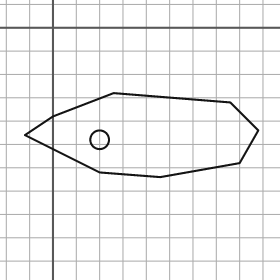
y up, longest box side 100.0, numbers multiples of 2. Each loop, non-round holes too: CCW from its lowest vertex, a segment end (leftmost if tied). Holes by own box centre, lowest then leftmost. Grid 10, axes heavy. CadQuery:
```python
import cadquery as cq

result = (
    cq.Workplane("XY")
    .moveTo(46.0, -64.0)
    .lineTo(80.0, -58.0)
    .lineTo(88.0, -44.0)
    .lineTo(76.0, -32.0)
    .lineTo(26.0, -28.0)
    .lineTo(0.0, -38.0)
    .lineTo(-12.0, -46.0)
    .lineTo(20.0, -62.0)
    .close()
    .moveTo(20.0, -48.0)
    .circle(4.0)
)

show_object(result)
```